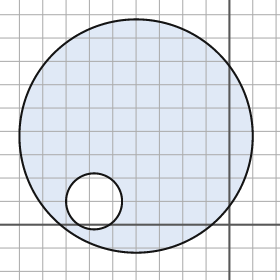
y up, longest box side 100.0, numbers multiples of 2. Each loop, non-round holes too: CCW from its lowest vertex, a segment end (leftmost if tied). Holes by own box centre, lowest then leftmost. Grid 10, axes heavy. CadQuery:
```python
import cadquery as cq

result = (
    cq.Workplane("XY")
    .moveTo(-40.0, 38.0)
    .circle(50.0)
    .moveTo(-58.0, 10.0)
    .circle(12.0)
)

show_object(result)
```